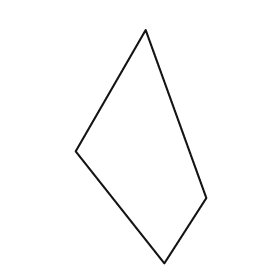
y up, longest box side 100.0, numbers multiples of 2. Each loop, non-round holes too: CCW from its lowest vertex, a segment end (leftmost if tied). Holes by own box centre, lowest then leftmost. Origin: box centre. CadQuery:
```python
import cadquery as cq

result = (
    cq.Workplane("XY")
    .moveTo(10.0, -50.0)
    .lineTo(28.0, -22.0)
    .lineTo(2.0, 50.0)
    .lineTo(-28.0, -2.0)
    .close()
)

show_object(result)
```